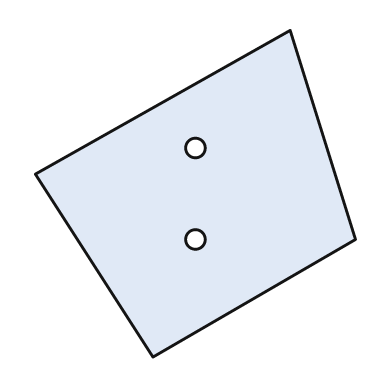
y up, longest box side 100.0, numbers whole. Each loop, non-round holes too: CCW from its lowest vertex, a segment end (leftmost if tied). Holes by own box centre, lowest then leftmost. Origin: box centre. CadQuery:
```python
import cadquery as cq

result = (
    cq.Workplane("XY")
    .moveTo(-13.0, -50.0)
    .lineTo(49.0, -14.0)
    .lineTo(29.0, 50.0)
    .lineTo(-49.0, 6.0)
    .close()
    .moveTo(0.0, -14.0)
    .circle(3.0)
    .moveTo(0.0, 14.0)
    .circle(3.0)
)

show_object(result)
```